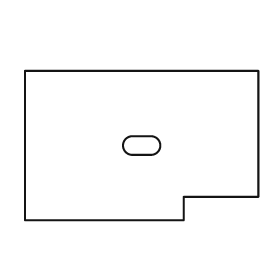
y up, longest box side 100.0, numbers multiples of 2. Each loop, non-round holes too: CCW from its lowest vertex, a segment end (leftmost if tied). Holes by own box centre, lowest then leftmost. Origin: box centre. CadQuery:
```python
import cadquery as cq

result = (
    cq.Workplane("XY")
    .moveTo(-50.0, -32.0)
    .lineTo(18.0, -32.0)
    .lineTo(18.0, -22.0)
    .lineTo(50.0, -22.0)
    .lineTo(50.0, 32.0)
    .lineTo(-50.0, 32.0)
    .close()
    .moveTo(-4.0, -4.0)
    .lineTo(4.0, -4.0)
    .threePointArc((8.0, 0.0), (4.0, 4.0))
    .lineTo(-4.0, 4.0)
    .threePointArc((-8.0, 0.0), (-4.0, -4.0))
    .close()
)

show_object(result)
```